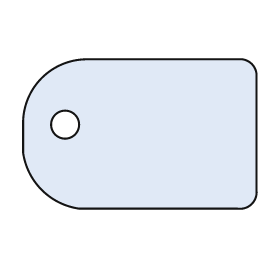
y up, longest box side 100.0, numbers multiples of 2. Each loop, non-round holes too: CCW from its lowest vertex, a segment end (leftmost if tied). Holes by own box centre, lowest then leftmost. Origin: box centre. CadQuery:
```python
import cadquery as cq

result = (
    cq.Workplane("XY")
    .moveTo(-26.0, -32.0)
    .lineTo(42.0, -32.0)
    .threePointArc((48.0, -30.0), (50.0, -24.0))
    .lineTo(50.0, 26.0)
    .threePointArc((48.0, 30.0), (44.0, 32.0))
    .lineTo(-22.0, 32.0)
    .threePointArc((-42.0, 24.0), (-50.0, 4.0))
    .lineTo(-50.0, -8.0)
    .threePointArc((-42.0, -24.0), (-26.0, -32.0))
    .close()
    .moveTo(-32.0, 4.0)
    .circle(6.0)
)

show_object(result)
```